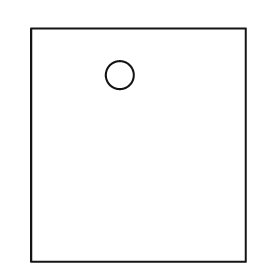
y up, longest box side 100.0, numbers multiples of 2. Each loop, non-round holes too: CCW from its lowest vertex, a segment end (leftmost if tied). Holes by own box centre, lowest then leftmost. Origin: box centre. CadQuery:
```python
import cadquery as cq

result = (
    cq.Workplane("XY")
    .moveTo(-46.0, -50.0)
    .lineTo(46.0, -50.0)
    .lineTo(46.0, 50.0)
    .lineTo(-46.0, 50.0)
    .close()
    .moveTo(-8.0, 30.0)
    .circle(6.0)
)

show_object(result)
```